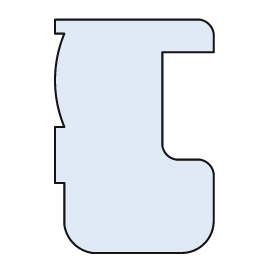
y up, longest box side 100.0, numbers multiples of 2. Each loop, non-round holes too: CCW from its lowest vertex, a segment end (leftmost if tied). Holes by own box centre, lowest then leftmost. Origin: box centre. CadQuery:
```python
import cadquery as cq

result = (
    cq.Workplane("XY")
    .moveTo(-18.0, -50.0)
    .lineTo(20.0, -50.0)
    .threePointArc((30.0, -46.0), (34.0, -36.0))
    .lineTo(34.0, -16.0)
    .threePointArc((32.0, -12.0), (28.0, -10.0))
    .lineTo(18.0, -10.0)
    .threePointArc((14.0, -8.0), (12.0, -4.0))
    .lineTo(12.0, 36.0)
    .lineTo(34.0, 36.0)
    .lineTo(34.0, 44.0)
    .threePointArc((32.0, 48.0), (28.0, 50.0))
    .lineTo(-34.0, 50.0)
    .lineTo(-34.0, 44.0)
    .lineTo(-30.0, 44.0)
    .threePointArc((-34.0, 24.0), (-30.0, 4.0))
    .lineTo(-34.0, 4.0)
    .lineTo(-34.0, -20.0)
    .lineTo(-30.0, -20.0)
    .lineTo(-30.0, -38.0)
    .threePointArc((-26.0, -46.0), (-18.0, -50.0))
    .close()
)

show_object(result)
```